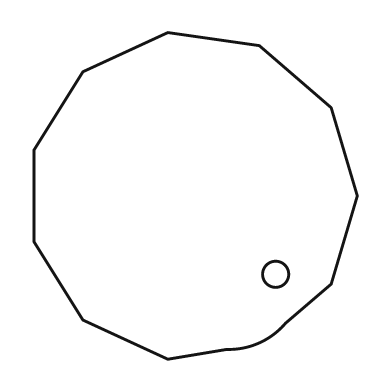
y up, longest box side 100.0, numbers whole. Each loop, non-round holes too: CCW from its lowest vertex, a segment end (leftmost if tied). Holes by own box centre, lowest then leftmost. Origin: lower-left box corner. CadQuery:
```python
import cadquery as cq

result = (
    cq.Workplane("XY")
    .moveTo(41.0, 0.0)
    .lineTo(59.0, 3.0)
    .threePointArc((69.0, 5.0), (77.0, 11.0))
    .lineTo(91.0, 23.0)
    .lineTo(99.0, 50.0)
    .lineTo(91.0, 77.0)
    .lineTo(69.0, 96.0)
    .lineTo(41.0, 100.0)
    .lineTo(15.0, 88.0)
    .lineTo(0.0, 64.0)
    .lineTo(0.0, 36.0)
    .lineTo(15.0, 12.0)
    .close()
    .moveTo(74.0, 26.0)
    .circle(4.0)
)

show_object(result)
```